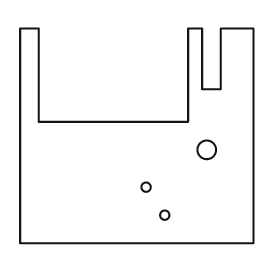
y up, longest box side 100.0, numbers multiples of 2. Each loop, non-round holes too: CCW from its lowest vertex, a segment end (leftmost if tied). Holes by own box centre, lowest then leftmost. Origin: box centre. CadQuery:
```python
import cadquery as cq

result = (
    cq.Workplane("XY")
    .moveTo(-50.0, -46.0)
    .lineTo(50.0, -46.0)
    .lineTo(50.0, 46.0)
    .lineTo(36.0, 46.0)
    .lineTo(36.0, 20.0)
    .lineTo(28.0, 20.0)
    .lineTo(28.0, 46.0)
    .lineTo(22.0, 46.0)
    .lineTo(22.0, 6.0)
    .lineTo(-42.0, 6.0)
    .lineTo(-42.0, 46.0)
    .lineTo(-50.0, 46.0)
    .close()
    .moveTo(12.0, -34.0)
    .circle(2.0)
    .moveTo(4.0, -22.0)
    .circle(2.0)
    .moveTo(30.0, -6.0)
    .circle(4.0)
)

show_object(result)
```